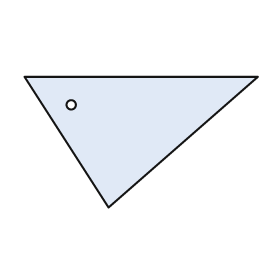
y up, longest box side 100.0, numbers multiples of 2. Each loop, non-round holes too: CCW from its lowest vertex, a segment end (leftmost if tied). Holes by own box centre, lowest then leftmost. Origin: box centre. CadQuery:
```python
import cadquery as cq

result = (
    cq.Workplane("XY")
    .moveTo(-14.0, -28.0)
    .lineTo(50.0, 28.0)
    .lineTo(-50.0, 28.0)
    .close()
    .moveTo(-30.0, 16.0)
    .circle(2.0)
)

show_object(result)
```